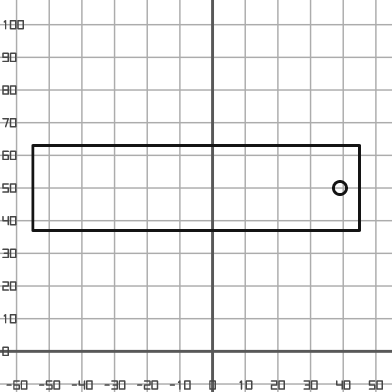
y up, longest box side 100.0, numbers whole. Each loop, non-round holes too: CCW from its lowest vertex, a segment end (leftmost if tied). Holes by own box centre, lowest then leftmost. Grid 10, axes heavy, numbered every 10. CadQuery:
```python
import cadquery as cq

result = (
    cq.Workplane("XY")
    .moveTo(-55.0, 37.0)
    .lineTo(45.0, 37.0)
    .lineTo(45.0, 63.0)
    .lineTo(-55.0, 63.0)
    .close()
    .moveTo(39.0, 50.0)
    .circle(2.0)
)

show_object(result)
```